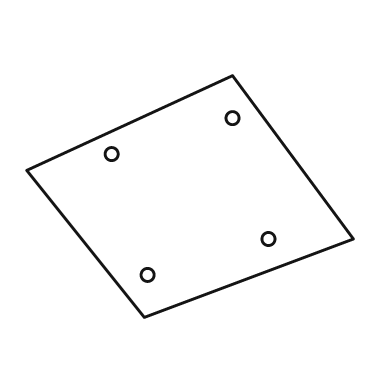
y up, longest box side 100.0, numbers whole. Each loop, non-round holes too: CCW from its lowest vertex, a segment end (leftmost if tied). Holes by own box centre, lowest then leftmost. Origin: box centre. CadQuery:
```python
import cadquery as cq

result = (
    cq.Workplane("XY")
    .moveTo(-14.0, -37.0)
    .lineTo(50.0, -13.0)
    .lineTo(13.0, 37.0)
    .lineTo(-50.0, 8.0)
    .close()
    .moveTo(-13.0, -24.0)
    .circle(2.0)
    .moveTo(24.0, -13.0)
    .circle(2.0)
    .moveTo(-24.0, 13.0)
    .circle(2.0)
    .moveTo(13.0, 24.0)
    .circle(2.0)
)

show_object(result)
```